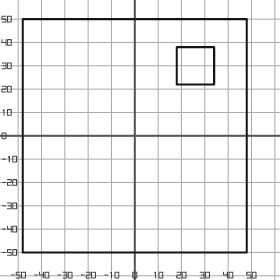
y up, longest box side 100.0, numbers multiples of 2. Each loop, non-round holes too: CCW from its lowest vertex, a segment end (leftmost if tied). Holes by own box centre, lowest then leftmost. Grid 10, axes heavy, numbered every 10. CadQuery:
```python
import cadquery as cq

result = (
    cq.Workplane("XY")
    .moveTo(-48.0, -50.0)
    .lineTo(48.0, -50.0)
    .lineTo(48.0, 50.0)
    .lineTo(-48.0, 50.0)
    .close()
    .moveTo(18.0, 22.0)
    .lineTo(34.0, 22.0)
    .lineTo(34.0, 38.0)
    .lineTo(18.0, 38.0)
    .close()
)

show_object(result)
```